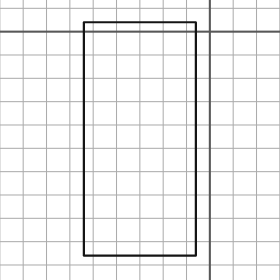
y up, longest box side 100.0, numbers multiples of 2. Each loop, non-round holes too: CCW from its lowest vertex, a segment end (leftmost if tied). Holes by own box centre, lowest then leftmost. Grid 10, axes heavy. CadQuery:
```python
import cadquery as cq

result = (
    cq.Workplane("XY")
    .moveTo(-54.0, -96.0)
    .lineTo(-6.0, -96.0)
    .lineTo(-6.0, 4.0)
    .lineTo(-54.0, 4.0)
    .close()
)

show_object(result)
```